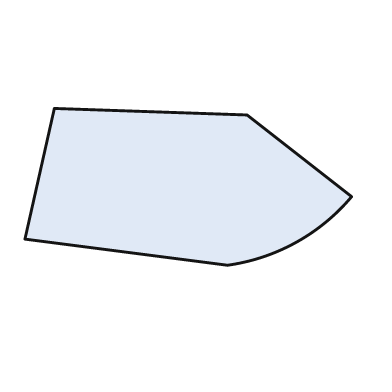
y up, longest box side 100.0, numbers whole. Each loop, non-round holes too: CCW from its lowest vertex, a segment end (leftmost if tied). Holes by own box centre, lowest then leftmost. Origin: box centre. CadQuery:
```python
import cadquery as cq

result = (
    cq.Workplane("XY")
    .moveTo(12.0, -24.0)
    .threePointArc((33.0, -17.0), (50.0, -3.0))
    .lineTo(18.0, 22.0)
    .lineTo(-41.0, 24.0)
    .lineTo(-50.0, -16.0)
    .close()
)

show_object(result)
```